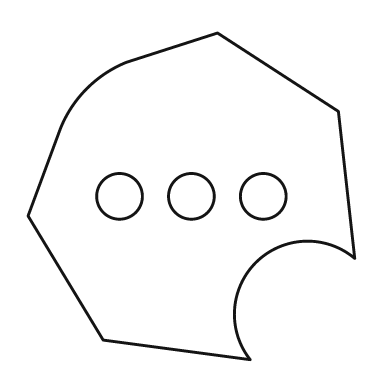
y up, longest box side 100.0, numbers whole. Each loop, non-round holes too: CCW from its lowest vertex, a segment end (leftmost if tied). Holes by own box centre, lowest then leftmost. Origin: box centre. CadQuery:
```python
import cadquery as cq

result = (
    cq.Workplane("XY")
    .moveTo(18.0, -50.0)
    .threePointArc((20.0, -20.0), (50.0, -19.0))
    .lineTo(45.0, 26.0)
    .lineTo(8.0, 50.0)
    .lineTo(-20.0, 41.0)
    .threePointArc((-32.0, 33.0), (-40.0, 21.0))
    .lineTo(-50.0, -6.0)
    .lineTo(-27.0, -44.0)
    .close()
    .moveTo(-22.0, 0.0)
    .circle(7.0)
    .moveTo(0.0, 0.0)
    .circle(7.0)
    .moveTo(22.0, 0.0)
    .circle(7.0)
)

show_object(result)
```